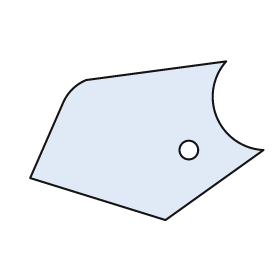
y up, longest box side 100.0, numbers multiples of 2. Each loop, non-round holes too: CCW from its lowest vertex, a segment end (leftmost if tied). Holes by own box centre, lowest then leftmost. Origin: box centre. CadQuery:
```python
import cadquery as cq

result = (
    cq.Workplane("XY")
    .moveTo(8.0, -34.0)
    .lineTo(50.0, -4.0)
    .threePointArc((30.0, 10.0), (34.0, 34.0))
    .lineTo(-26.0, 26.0)
    .threePointArc((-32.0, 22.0), (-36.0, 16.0))
    .lineTo(-50.0, -16.0)
    .close()
    .moveTo(18.0, -4.0)
    .circle(4.0)
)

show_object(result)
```